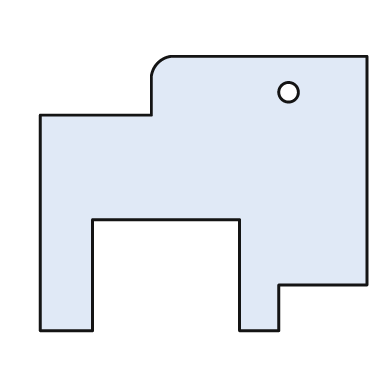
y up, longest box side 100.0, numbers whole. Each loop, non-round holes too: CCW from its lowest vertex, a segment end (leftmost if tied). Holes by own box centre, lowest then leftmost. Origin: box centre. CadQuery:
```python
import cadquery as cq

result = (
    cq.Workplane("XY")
    .moveTo(-50.0, -42.0)
    .lineTo(-34.0, -42.0)
    .lineTo(-34.0, -8.0)
    .lineTo(11.0, -8.0)
    .lineTo(11.0, -42.0)
    .lineTo(23.0, -42.0)
    .lineTo(23.0, -28.0)
    .lineTo(50.0, -28.0)
    .lineTo(50.0, 42.0)
    .lineTo(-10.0, 42.0)
    .threePointArc((-14.0, 40.0), (-16.0, 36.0))
    .lineTo(-16.0, 24.0)
    .lineTo(-50.0, 24.0)
    .close()
    .moveTo(26.0, 31.0)
    .circle(3.0)
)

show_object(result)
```